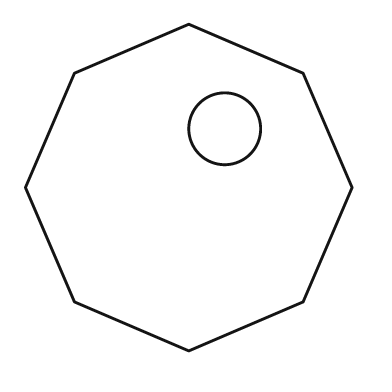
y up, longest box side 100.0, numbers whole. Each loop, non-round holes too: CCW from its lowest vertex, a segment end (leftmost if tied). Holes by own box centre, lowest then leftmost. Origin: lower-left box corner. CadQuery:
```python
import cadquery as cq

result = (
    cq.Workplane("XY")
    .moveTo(50.0, 0.0)
    .lineTo(85.0, 15.0)
    .lineTo(100.0, 50.0)
    .lineTo(85.0, 85.0)
    .lineTo(50.0, 100.0)
    .lineTo(15.0, 85.0)
    .lineTo(0.0, 50.0)
    .lineTo(15.0, 15.0)
    .close()
    .moveTo(61.0, 68.0)
    .circle(11.0)
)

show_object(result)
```